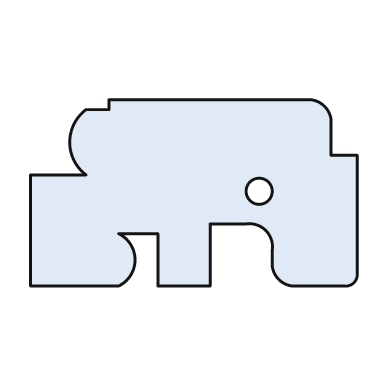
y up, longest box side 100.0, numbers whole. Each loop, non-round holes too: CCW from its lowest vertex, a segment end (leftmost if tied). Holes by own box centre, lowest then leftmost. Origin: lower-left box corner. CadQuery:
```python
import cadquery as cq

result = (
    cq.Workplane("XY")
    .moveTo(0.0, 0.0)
    .lineTo(27.0, 0.0)
    .threePointArc((32.0, 8.0), (27.0, 16.0))
    .lineTo(39.0, 16.0)
    .lineTo(39.0, 0.0)
    .lineTo(55.0, 0.0)
    .lineTo(55.0, 19.0)
    .lineTo(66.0, 19.0)
    .threePointArc((72.0, 17.0), (74.0, 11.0))
    .lineTo(74.0, 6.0)
    .threePointArc((76.0, 2.0), (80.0, 0.0))
    .lineTo(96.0, 0.0)
    .threePointArc((99.0, 1.0), (100.0, 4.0))
    .lineTo(100.0, 40.0)
    .lineTo(92.0, 40.0)
    .lineTo(92.0, 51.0)
    .threePointArc((90.0, 55.0), (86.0, 57.0))
    .lineTo(24.0, 57.0)
    .lineTo(24.0, 54.0)
    .lineTo(17.0, 54.0)
    .threePointArc((12.0, 44.0), (17.0, 34.0))
    .lineTo(0.0, 34.0)
    .close()
    .moveTo(70.0, 29.0)
    .circle(4.0)
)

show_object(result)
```